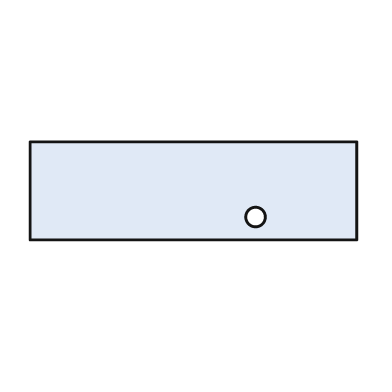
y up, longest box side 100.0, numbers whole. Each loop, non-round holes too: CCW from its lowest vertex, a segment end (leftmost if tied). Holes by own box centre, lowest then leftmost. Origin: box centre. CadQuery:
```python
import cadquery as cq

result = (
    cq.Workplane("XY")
    .moveTo(-50.0, -15.0)
    .lineTo(50.0, -15.0)
    .lineTo(50.0, 15.0)
    .lineTo(-50.0, 15.0)
    .close()
    .moveTo(19.0, -8.0)
    .circle(3.0)
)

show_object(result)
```